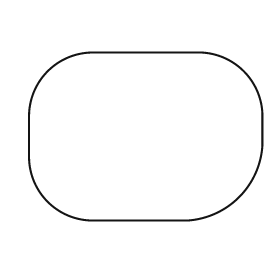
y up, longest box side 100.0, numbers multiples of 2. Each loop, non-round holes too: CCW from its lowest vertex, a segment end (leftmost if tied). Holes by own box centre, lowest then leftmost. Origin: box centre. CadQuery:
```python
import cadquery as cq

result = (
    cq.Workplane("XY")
    .moveTo(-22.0, -36.0)
    .lineTo(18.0, -36.0)
    .threePointArc((40.0, -26.0), (50.0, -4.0))
    .lineTo(50.0, 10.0)
    .threePointArc((42.0, 28.0), (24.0, 36.0))
    .lineTo(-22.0, 36.0)
    .threePointArc((-42.0, 28.0), (-50.0, 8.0))
    .lineTo(-50.0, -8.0)
    .threePointArc((-42.0, -28.0), (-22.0, -36.0))
    .close()
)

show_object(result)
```